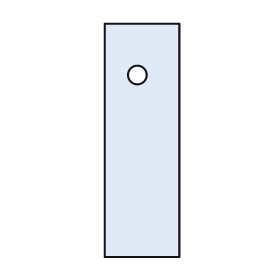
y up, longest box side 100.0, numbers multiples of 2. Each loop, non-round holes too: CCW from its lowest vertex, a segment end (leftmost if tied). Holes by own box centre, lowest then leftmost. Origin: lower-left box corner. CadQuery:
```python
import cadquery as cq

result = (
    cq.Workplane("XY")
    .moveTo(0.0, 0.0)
    .lineTo(32.0, 0.0)
    .lineTo(32.0, 100.0)
    .lineTo(0.0, 100.0)
    .close()
    .moveTo(14.0, 78.0)
    .circle(4.0)
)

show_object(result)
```